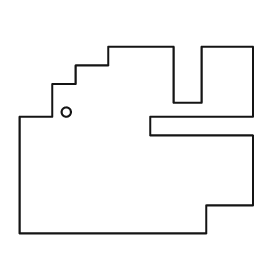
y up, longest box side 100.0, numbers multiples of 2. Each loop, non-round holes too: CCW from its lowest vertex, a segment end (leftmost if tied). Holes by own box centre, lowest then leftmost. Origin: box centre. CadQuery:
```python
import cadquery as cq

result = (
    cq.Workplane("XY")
    .moveTo(-50.0, -40.0)
    .lineTo(30.0, -40.0)
    .lineTo(30.0, -28.0)
    .lineTo(50.0, -28.0)
    .lineTo(50.0, 2.0)
    .lineTo(6.0, 2.0)
    .lineTo(6.0, 10.0)
    .lineTo(50.0, 10.0)
    .lineTo(50.0, 40.0)
    .lineTo(28.0, 40.0)
    .lineTo(28.0, 16.0)
    .lineTo(16.0, 16.0)
    .lineTo(16.0, 40.0)
    .lineTo(-12.0, 40.0)
    .lineTo(-12.0, 32.0)
    .lineTo(-26.0, 32.0)
    .lineTo(-26.0, 24.0)
    .lineTo(-36.0, 24.0)
    .lineTo(-36.0, 10.0)
    .lineTo(-50.0, 10.0)
    .close()
    .moveTo(-30.0, 12.0)
    .circle(2.0)
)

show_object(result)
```